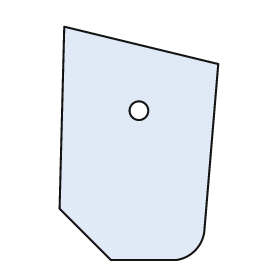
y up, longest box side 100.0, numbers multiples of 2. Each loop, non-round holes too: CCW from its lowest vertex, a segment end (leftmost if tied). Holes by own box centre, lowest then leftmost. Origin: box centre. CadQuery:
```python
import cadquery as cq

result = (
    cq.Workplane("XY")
    .moveTo(-12.0, -50.0)
    .lineTo(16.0, -50.0)
    .threePointArc((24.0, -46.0), (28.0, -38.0))
    .lineTo(34.0, 34.0)
    .lineTo(-32.0, 50.0)
    .lineTo(-34.0, -28.0)
    .close()
    .moveTo(0.0, 14.0)
    .circle(4.0)
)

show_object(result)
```